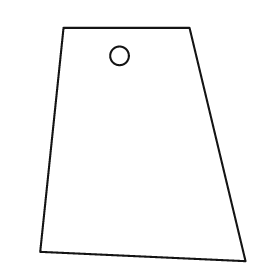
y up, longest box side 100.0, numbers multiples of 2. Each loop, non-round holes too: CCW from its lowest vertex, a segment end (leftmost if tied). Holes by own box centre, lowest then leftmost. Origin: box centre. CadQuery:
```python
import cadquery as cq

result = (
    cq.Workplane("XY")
    .moveTo(44.0, -50.0)
    .lineTo(20.0, 50.0)
    .lineTo(-34.0, 50.0)
    .lineTo(-44.0, -46.0)
    .close()
    .moveTo(-10.0, 38.0)
    .circle(4.0)
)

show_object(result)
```